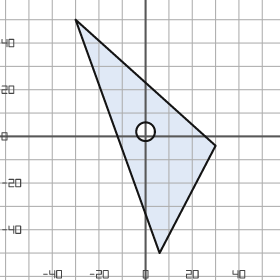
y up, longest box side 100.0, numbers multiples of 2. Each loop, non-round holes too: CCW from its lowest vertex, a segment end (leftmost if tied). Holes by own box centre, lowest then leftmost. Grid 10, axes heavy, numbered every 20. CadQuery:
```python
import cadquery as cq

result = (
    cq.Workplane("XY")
    .moveTo(6.0, -50.0)
    .lineTo(30.0, -4.0)
    .lineTo(-30.0, 50.0)
    .close()
    .moveTo(0.0, 2.0)
    .circle(4.0)
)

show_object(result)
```